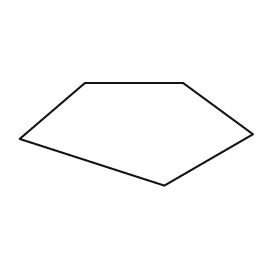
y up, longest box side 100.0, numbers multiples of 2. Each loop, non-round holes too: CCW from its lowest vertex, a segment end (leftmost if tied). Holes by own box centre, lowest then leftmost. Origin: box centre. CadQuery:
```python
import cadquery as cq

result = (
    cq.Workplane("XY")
    .moveTo(12.0, -22.0)
    .lineTo(50.0, 0.0)
    .lineTo(20.0, 22.0)
    .lineTo(-22.0, 22.0)
    .lineTo(-50.0, -2.0)
    .close()
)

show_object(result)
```